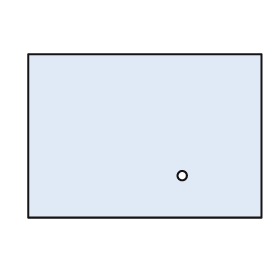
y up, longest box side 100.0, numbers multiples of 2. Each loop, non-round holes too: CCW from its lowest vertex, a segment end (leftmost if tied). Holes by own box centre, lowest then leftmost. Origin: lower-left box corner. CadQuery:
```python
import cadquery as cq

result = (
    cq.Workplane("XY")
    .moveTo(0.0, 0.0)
    .lineTo(100.0, 0.0)
    .lineTo(100.0, 70.0)
    .lineTo(0.0, 70.0)
    .close()
    .moveTo(66.0, 18.0)
    .circle(2.0)
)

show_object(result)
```